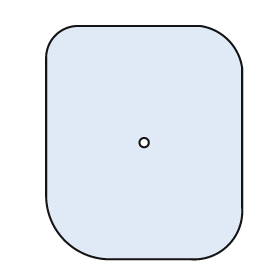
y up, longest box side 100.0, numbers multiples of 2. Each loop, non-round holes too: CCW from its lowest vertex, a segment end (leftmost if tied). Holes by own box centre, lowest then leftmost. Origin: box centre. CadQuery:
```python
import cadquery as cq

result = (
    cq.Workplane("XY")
    .moveTo(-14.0, -50.0)
    .lineTo(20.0, -50.0)
    .threePointArc((36.0, -44.0), (42.0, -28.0))
    .lineTo(42.0, 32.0)
    .threePointArc((36.0, 44.0), (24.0, 50.0))
    .lineTo(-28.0, 50.0)
    .threePointArc((-38.0, 46.0), (-42.0, 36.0))
    .lineTo(-42.0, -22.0)
    .threePointArc((-34.0, -42.0), (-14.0, -50.0))
    .close()
    .moveTo(0.0, 0.0)
    .circle(2.0)
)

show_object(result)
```